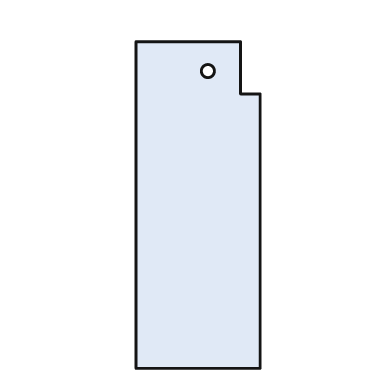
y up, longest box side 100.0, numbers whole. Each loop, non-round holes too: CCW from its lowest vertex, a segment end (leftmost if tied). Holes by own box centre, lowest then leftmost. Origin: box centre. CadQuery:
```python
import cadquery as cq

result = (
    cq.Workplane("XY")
    .moveTo(-19.0, -50.0)
    .lineTo(19.0, -50.0)
    .lineTo(19.0, 34.0)
    .lineTo(13.0, 34.0)
    .lineTo(13.0, 50.0)
    .lineTo(-19.0, 50.0)
    .close()
    .moveTo(3.0, 41.0)
    .circle(2.0)
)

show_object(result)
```